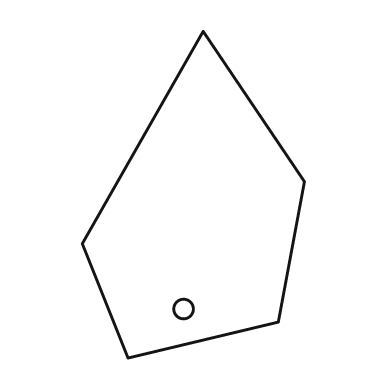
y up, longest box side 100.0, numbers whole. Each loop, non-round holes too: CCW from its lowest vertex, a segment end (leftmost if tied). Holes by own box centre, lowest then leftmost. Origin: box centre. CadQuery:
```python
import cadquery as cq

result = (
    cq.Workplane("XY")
    .moveTo(-20.0, -50.0)
    .lineTo(26.0, -39.0)
    .lineTo(34.0, 4.0)
    .lineTo(3.0, 50.0)
    .lineTo(-34.0, -15.0)
    .close()
    .moveTo(-3.0, -35.0)
    .circle(3.0)
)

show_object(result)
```